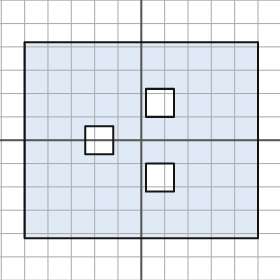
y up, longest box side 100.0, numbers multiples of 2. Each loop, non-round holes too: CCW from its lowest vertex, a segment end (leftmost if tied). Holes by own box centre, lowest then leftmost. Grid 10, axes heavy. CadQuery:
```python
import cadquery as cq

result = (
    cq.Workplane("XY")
    .moveTo(-50.0, -42.0)
    .lineTo(50.0, -42.0)
    .lineTo(50.0, 42.0)
    .lineTo(-50.0, 42.0)
    .close()
    .moveTo(2.0, -22.0)
    .lineTo(14.0, -22.0)
    .lineTo(14.0, -10.0)
    .lineTo(2.0, -10.0)
    .close()
    .moveTo(-24.0, -6.0)
    .lineTo(-12.0, -6.0)
    .lineTo(-12.0, 6.0)
    .lineTo(-24.0, 6.0)
    .close()
    .moveTo(2.0, 10.0)
    .lineTo(14.0, 10.0)
    .lineTo(14.0, 22.0)
    .lineTo(2.0, 22.0)
    .close()
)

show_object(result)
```